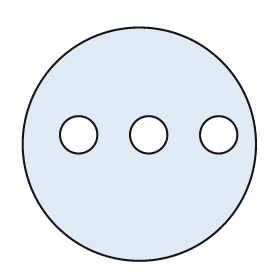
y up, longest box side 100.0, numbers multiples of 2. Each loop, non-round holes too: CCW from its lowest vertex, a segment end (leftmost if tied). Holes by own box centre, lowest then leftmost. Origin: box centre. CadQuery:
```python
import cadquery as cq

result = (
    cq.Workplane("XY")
    .moveTo(0.0, 0.0)
    .circle(50.0)
    .moveTo(-26.0, 4.0)
    .circle(8.0)
    .moveTo(4.0, 4.0)
    .circle(8.0)
    .moveTo(34.0, 4.0)
    .circle(8.0)
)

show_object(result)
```